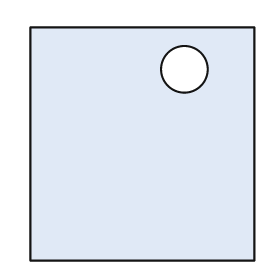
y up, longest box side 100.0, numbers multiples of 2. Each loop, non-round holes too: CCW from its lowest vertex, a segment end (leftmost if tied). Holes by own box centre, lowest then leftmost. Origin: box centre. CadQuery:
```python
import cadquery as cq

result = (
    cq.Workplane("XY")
    .moveTo(-48.0, -50.0)
    .lineTo(48.0, -50.0)
    .lineTo(48.0, 50.0)
    .lineTo(-48.0, 50.0)
    .close()
    .moveTo(18.0, 32.0)
    .circle(10.0)
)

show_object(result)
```